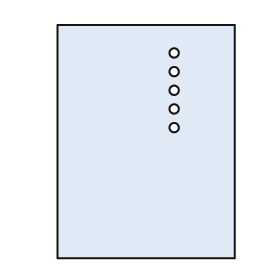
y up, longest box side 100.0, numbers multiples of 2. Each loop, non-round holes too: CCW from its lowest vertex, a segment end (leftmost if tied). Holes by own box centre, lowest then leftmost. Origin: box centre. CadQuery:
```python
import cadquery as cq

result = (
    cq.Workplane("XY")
    .moveTo(-38.0, -50.0)
    .lineTo(38.0, -50.0)
    .lineTo(38.0, 50.0)
    .lineTo(-38.0, 50.0)
    .close()
    .moveTo(12.0, 6.0)
    .circle(2.0)
    .moveTo(12.0, 14.0)
    .circle(2.0)
    .moveTo(12.0, 22.0)
    .circle(2.0)
    .moveTo(12.0, 30.0)
    .circle(2.0)
    .moveTo(12.0, 38.0)
    .circle(2.0)
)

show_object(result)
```